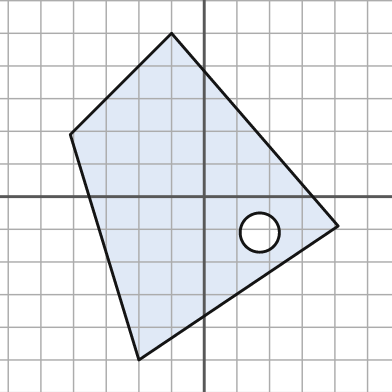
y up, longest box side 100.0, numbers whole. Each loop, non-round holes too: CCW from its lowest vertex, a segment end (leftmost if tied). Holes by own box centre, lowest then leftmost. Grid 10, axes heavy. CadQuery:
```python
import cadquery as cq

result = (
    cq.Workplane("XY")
    .moveTo(-20.0, -50.0)
    .lineTo(41.0, -9.0)
    .lineTo(-10.0, 50.0)
    .lineTo(-41.0, 19.0)
    .close()
    .moveTo(17.0, -11.0)
    .circle(6.0)
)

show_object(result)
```